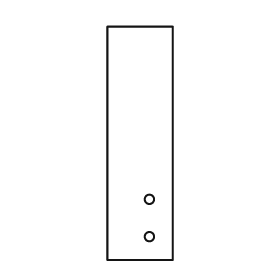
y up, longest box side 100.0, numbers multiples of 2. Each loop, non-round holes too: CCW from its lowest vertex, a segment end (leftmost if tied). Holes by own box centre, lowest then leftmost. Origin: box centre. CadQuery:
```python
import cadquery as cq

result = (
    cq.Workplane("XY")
    .moveTo(-14.0, -50.0)
    .lineTo(14.0, -50.0)
    .lineTo(14.0, 50.0)
    .lineTo(-14.0, 50.0)
    .close()
    .moveTo(4.0, -40.0)
    .circle(2.0)
    .moveTo(4.0, -24.0)
    .circle(2.0)
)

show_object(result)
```